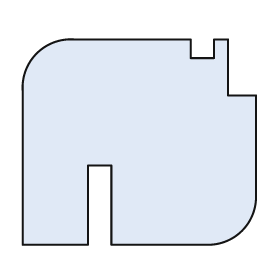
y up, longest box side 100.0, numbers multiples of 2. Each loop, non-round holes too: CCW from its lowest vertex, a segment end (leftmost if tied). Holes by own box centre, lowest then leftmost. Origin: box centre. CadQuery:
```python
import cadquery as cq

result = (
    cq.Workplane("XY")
    .moveTo(-50.0, -44.0)
    .lineTo(-22.0, -44.0)
    .lineTo(-22.0, -10.0)
    .lineTo(-12.0, -10.0)
    .lineTo(-12.0, -44.0)
    .lineTo(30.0, -44.0)
    .threePointArc((44.0, -38.0), (50.0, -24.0))
    .lineTo(50.0, 20.0)
    .lineTo(38.0, 20.0)
    .lineTo(38.0, 44.0)
    .lineTo(32.0, 44.0)
    .lineTo(32.0, 36.0)
    .lineTo(22.0, 36.0)
    .lineTo(22.0, 44.0)
    .lineTo(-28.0, 44.0)
    .threePointArc((-44.0, 38.0), (-50.0, 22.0))
    .close()
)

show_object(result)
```